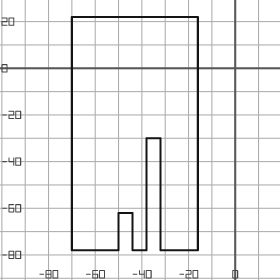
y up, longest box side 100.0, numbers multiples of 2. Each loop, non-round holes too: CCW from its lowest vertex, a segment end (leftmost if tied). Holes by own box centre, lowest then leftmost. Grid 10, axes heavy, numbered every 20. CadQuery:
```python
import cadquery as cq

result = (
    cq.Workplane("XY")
    .moveTo(-70.0, -78.0)
    .lineTo(-50.0, -78.0)
    .lineTo(-50.0, -62.0)
    .lineTo(-44.0, -62.0)
    .lineTo(-44.0, -78.0)
    .lineTo(-38.0, -78.0)
    .lineTo(-38.0, -30.0)
    .lineTo(-32.0, -30.0)
    .lineTo(-32.0, -78.0)
    .lineTo(-16.0, -78.0)
    .lineTo(-16.0, 22.0)
    .lineTo(-70.0, 22.0)
    .close()
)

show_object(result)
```